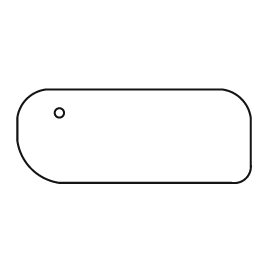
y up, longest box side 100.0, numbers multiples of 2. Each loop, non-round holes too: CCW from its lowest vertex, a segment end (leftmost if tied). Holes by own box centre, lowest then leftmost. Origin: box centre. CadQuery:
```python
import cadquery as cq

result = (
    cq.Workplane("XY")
    .moveTo(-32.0, -20.0)
    .lineTo(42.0, -20.0)
    .threePointArc((48.0, -18.0), (50.0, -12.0))
    .lineTo(50.0, 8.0)
    .threePointArc((46.0, 16.0), (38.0, 20.0))
    .lineTo(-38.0, 20.0)
    .threePointArc((-46.0, 16.0), (-50.0, 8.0))
    .lineTo(-50.0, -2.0)
    .threePointArc((-44.0, -14.0), (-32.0, -20.0))
    .close()
    .moveTo(-32.0, 10.0)
    .circle(2.0)
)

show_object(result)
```